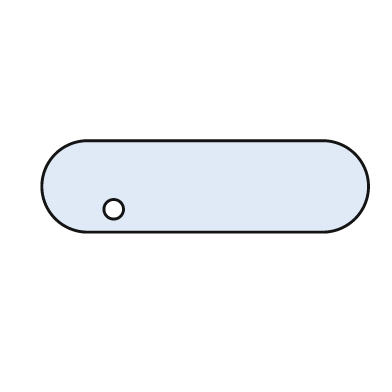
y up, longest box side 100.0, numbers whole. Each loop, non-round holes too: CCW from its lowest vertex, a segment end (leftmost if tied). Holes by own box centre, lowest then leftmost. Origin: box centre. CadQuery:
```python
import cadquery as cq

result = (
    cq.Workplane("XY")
    .moveTo(-36.0, -14.0)
    .lineTo(36.0, -14.0)
    .threePointArc((50.0, 0.0), (36.0, 14.0))
    .lineTo(-36.0, 14.0)
    .threePointArc((-50.0, 0.0), (-36.0, -14.0))
    .close()
    .moveTo(-28.0, -7.0)
    .circle(3.0)
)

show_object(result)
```